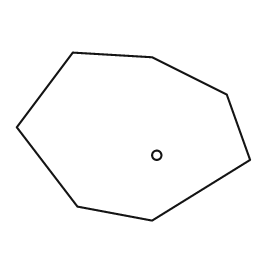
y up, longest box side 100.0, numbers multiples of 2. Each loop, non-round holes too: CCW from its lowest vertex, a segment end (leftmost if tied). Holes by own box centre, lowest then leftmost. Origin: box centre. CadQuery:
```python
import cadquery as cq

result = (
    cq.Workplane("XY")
    .moveTo(8.0, -36.0)
    .lineTo(50.0, -10.0)
    .lineTo(40.0, 18.0)
    .lineTo(8.0, 34.0)
    .lineTo(-26.0, 36.0)
    .lineTo(-50.0, 4.0)
    .lineTo(-24.0, -30.0)
    .close()
    .moveTo(10.0, -8.0)
    .circle(2.0)
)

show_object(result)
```